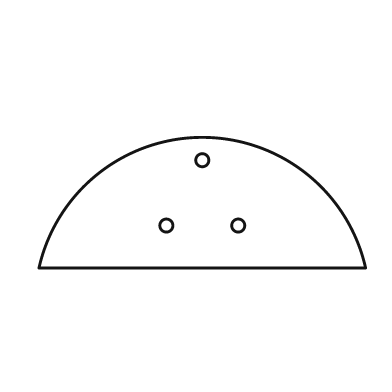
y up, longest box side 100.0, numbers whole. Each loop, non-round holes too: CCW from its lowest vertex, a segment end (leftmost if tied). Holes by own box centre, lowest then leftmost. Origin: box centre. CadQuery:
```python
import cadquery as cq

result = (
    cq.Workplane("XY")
    .moveTo(-50.0, -20.0)
    .lineTo(50.0, -20.0)
    .threePointArc((0.0, 20.0), (-50.0, -20.0))
    .close()
    .moveTo(-11.0, -7.0)
    .circle(2.0)
    .moveTo(11.0, -7.0)
    .circle(2.0)
    .moveTo(0.0, 13.0)
    .circle(2.0)
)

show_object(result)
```